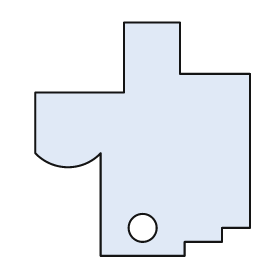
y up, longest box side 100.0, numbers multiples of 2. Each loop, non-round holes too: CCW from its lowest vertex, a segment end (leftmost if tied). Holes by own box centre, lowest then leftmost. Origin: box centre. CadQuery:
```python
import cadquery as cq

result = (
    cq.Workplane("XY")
    .moveTo(-18.0, -50.0)
    .lineTo(18.0, -50.0)
    .lineTo(18.0, -44.0)
    .lineTo(34.0, -44.0)
    .lineTo(34.0, -38.0)
    .lineTo(46.0, -38.0)
    .lineTo(46.0, 28.0)
    .lineTo(16.0, 28.0)
    .lineTo(16.0, 50.0)
    .lineTo(-8.0, 50.0)
    .lineTo(-8.0, 20.0)
    .lineTo(-46.0, 20.0)
    .lineTo(-46.0, -6.0)
    .threePointArc((-32.0, -12.0), (-18.0, -6.0))
    .close()
    .moveTo(0.0, -38.0)
    .circle(6.0)
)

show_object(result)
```